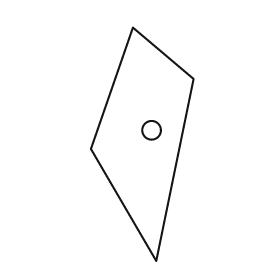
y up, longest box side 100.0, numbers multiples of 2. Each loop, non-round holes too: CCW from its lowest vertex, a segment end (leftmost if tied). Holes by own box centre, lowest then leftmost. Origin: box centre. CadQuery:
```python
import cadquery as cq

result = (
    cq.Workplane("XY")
    .moveTo(6.0, -50.0)
    .lineTo(22.0, 28.0)
    .lineTo(-4.0, 50.0)
    .lineTo(-22.0, -2.0)
    .close()
    .moveTo(4.0, 6.0)
    .circle(4.0)
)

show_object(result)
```